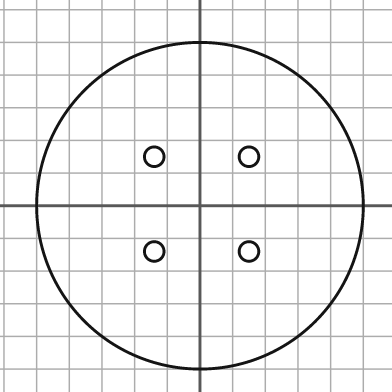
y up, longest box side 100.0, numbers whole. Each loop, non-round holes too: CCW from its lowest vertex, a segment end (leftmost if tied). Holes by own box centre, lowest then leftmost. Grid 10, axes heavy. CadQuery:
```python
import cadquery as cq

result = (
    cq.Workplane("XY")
    .moveTo(0.0, 0.0)
    .circle(50.0)
    .moveTo(-14.0, -14.0)
    .circle(3.0)
    .moveTo(15.0, -14.0)
    .circle(3.0)
    .moveTo(-14.0, 15.0)
    .circle(3.0)
    .moveTo(15.0, 15.0)
    .circle(3.0)
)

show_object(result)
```